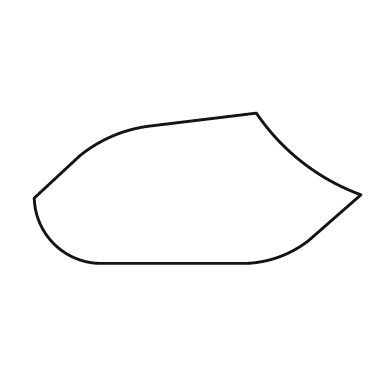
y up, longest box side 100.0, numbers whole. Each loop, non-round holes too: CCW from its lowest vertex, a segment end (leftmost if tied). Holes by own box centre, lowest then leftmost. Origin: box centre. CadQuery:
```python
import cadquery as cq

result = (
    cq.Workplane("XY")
    .moveTo(-30.0, -23.0)
    .lineTo(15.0, -23.0)
    .threePointArc((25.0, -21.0), (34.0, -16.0))
    .lineTo(50.0, -2.0)
    .threePointArc((32.0, 8.0), (18.0, 23.0))
    .lineTo(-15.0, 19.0)
    .threePointArc((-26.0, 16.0), (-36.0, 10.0))
    .lineTo(-50.0, -3.0)
    .threePointArc((-44.0, -17.0), (-30.0, -23.0))
    .close()
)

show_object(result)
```